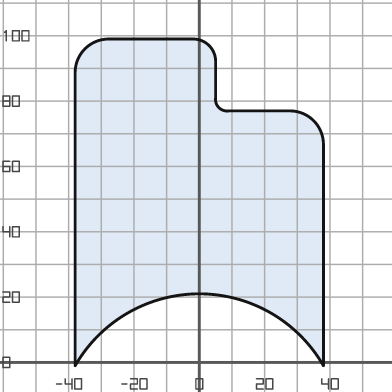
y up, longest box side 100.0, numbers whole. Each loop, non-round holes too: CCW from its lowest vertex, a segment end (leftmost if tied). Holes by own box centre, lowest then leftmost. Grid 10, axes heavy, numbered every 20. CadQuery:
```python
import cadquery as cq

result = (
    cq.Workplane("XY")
    .moveTo(-38.0, -1.0)
    .threePointArc((0.0, 21.0), (38.0, -1.0))
    .lineTo(38.0, 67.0)
    .threePointArc((35.0, 74.0), (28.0, 77.0))
    .lineTo(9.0, 77.0)
    .threePointArc((6.0, 78.0), (5.0, 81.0))
    .lineTo(5.0, 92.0)
    .threePointArc((3.0, 97.0), (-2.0, 99.0))
    .lineTo(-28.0, 99.0)
    .threePointArc((-35.0, 96.0), (-38.0, 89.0))
    .close()
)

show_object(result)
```